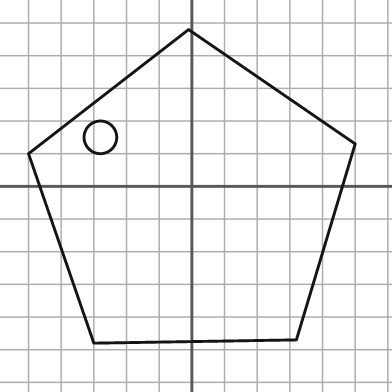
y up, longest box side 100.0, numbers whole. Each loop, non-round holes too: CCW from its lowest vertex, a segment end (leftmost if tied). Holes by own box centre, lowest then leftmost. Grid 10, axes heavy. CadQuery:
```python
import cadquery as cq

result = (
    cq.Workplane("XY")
    .moveTo(-30.0, -48.0)
    .lineTo(32.0, -47.0)
    .lineTo(50.0, 13.0)
    .lineTo(-1.0, 48.0)
    .lineTo(-50.0, 10.0)
    .close()
    .moveTo(-28.0, 15.0)
    .circle(5.0)
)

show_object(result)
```